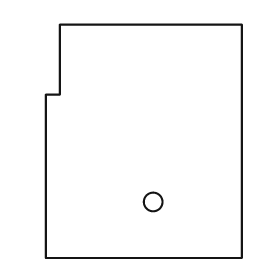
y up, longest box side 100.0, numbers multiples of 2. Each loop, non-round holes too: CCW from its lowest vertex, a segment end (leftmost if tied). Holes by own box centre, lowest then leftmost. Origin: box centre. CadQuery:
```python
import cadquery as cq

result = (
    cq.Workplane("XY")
    .moveTo(-42.0, -50.0)
    .lineTo(42.0, -50.0)
    .lineTo(42.0, 50.0)
    .lineTo(-36.0, 50.0)
    .lineTo(-36.0, 20.0)
    .lineTo(-42.0, 20.0)
    .close()
    .moveTo(4.0, -26.0)
    .circle(4.0)
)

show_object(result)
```